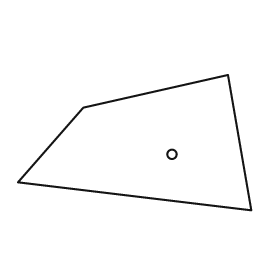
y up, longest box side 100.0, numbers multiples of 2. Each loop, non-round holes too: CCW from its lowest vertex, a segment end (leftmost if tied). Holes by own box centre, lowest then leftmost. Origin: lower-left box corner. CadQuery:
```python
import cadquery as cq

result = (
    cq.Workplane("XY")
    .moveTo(100.0, 0.0)
    .lineTo(90.0, 58.0)
    .lineTo(28.0, 44.0)
    .lineTo(0.0, 12.0)
    .close()
    .moveTo(66.0, 24.0)
    .circle(2.0)
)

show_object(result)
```